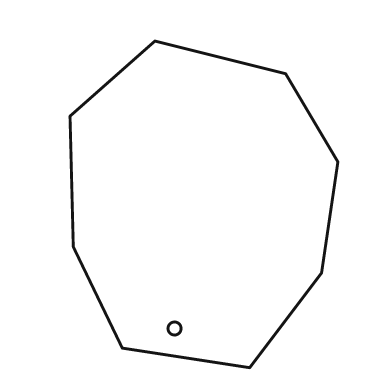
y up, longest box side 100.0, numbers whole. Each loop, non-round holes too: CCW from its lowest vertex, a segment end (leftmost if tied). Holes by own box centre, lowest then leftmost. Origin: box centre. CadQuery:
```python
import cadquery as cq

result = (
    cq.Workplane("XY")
    .moveTo(14.0, -50.0)
    .lineTo(36.0, -21.0)
    .lineTo(41.0, 13.0)
    .lineTo(25.0, 40.0)
    .lineTo(-15.0, 50.0)
    .lineTo(-41.0, 27.0)
    .lineTo(-40.0, -13.0)
    .lineTo(-25.0, -44.0)
    .close()
    .moveTo(-9.0, -38.0)
    .circle(2.0)
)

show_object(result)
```